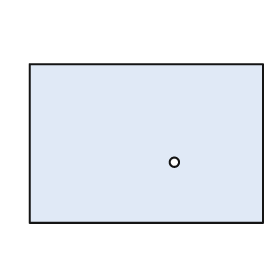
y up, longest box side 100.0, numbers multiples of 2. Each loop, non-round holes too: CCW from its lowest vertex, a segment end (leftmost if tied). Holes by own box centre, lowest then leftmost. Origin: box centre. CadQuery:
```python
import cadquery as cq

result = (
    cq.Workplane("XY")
    .moveTo(-50.0, -34.0)
    .lineTo(50.0, -34.0)
    .lineTo(50.0, 34.0)
    .lineTo(-50.0, 34.0)
    .close()
    .moveTo(12.0, -8.0)
    .circle(2.0)
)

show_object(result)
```